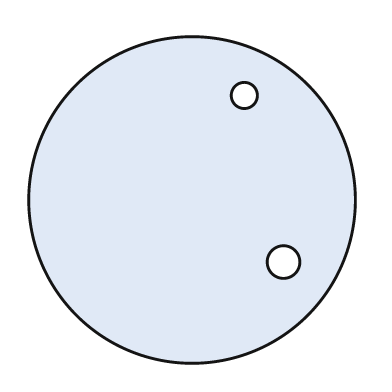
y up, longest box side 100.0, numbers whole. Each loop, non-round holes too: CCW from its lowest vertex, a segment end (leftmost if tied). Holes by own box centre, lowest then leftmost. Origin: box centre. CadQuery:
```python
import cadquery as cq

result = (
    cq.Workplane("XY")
    .moveTo(0.0, 0.0)
    .circle(50.0)
    .moveTo(28.0, -19.0)
    .circle(5.0)
    .moveTo(16.0, 32.0)
    .circle(4.0)
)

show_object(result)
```